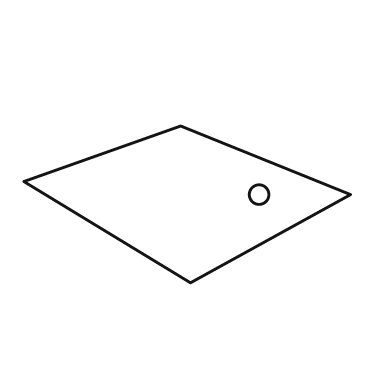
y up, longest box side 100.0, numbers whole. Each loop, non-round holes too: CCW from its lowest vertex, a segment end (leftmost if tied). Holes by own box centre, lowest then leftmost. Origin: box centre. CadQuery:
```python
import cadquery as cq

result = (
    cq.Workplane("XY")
    .moveTo(1.0, -24.0)
    .lineTo(50.0, 3.0)
    .lineTo(-2.0, 24.0)
    .lineTo(-50.0, 7.0)
    .close()
    .moveTo(22.0, 3.0)
    .circle(3.0)
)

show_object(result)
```